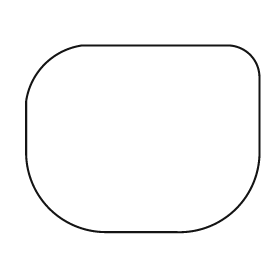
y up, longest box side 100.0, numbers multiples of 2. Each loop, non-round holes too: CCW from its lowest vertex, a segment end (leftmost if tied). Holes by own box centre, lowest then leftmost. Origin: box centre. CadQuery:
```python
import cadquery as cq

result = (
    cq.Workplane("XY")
    .moveTo(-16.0, -40.0)
    .lineTo(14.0, -40.0)
    .threePointArc((40.0, -30.0), (50.0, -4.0))
    .lineTo(50.0, 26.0)
    .threePointArc((46.0, 36.0), (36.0, 40.0))
    .lineTo(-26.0, 40.0)
    .threePointArc((-42.0, 32.0), (-50.0, 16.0))
    .lineTo(-50.0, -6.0)
    .threePointArc((-40.0, -30.0), (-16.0, -40.0))
    .close()
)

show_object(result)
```